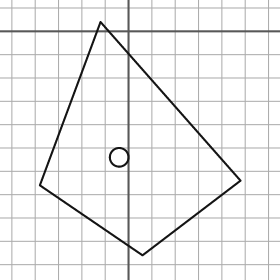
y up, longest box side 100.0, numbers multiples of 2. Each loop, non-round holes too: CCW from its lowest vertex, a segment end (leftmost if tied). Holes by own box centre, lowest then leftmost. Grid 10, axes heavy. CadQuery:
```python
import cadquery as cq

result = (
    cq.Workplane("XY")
    .moveTo(6.0, -96.0)
    .lineTo(48.0, -64.0)
    .lineTo(-12.0, 4.0)
    .lineTo(-38.0, -66.0)
    .close()
    .moveTo(-4.0, -54.0)
    .circle(4.0)
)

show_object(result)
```